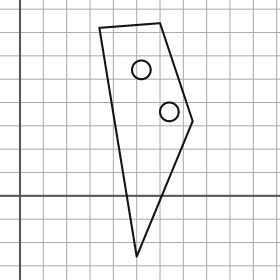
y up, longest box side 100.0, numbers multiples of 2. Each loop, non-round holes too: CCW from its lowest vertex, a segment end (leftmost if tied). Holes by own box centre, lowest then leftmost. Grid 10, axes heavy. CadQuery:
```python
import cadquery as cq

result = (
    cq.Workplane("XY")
    .moveTo(50.0, -26.0)
    .lineTo(74.0, 32.0)
    .lineTo(60.0, 74.0)
    .lineTo(34.0, 72.0)
    .close()
    .moveTo(64.0, 36.0)
    .circle(4.0)
    .moveTo(52.0, 54.0)
    .circle(4.0)
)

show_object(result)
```